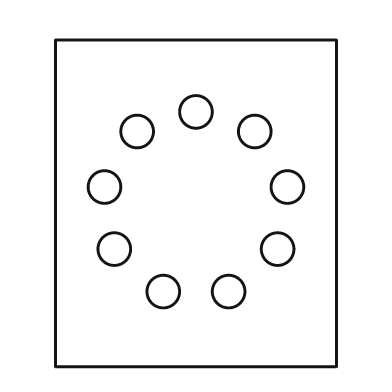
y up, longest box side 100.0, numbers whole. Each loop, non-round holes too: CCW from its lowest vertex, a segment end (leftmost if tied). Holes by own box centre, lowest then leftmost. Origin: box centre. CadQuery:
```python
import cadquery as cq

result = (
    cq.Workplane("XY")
    .moveTo(-43.0, -50.0)
    .lineTo(43.0, -50.0)
    .lineTo(43.0, 50.0)
    .lineTo(-43.0, 50.0)
    .close()
    .moveTo(-10.0, -27.0)
    .circle(5.0)
    .moveTo(10.0, -27.0)
    .circle(5.0)
    .moveTo(-25.0, -14.0)
    .circle(5.0)
    .moveTo(25.0, -14.0)
    .circle(5.0)
    .moveTo(-28.0, 5.0)
    .circle(5.0)
    .moveTo(28.0, 5.0)
    .circle(5.0)
    .moveTo(-18.0, 22.0)
    .circle(5.0)
    .moveTo(18.0, 22.0)
    .circle(5.0)
    .moveTo(0.0, 28.0)
    .circle(5.0)
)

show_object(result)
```